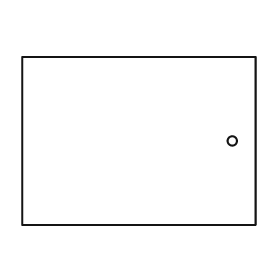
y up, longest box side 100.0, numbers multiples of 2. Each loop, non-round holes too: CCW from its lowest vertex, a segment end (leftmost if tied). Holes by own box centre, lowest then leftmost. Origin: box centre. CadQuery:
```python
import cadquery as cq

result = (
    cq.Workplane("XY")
    .moveTo(-50.0, -36.0)
    .lineTo(50.0, -36.0)
    .lineTo(50.0, 36.0)
    .lineTo(-50.0, 36.0)
    .close()
    .moveTo(40.0, 0.0)
    .circle(2.0)
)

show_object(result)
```